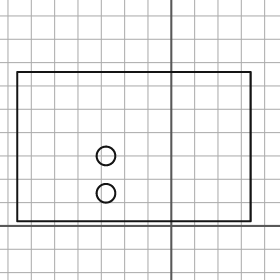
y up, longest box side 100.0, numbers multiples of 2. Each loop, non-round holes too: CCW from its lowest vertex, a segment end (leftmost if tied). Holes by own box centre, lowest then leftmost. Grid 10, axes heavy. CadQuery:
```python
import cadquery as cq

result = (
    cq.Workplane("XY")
    .moveTo(-66.0, 2.0)
    .lineTo(34.0, 2.0)
    .lineTo(34.0, 66.0)
    .lineTo(-66.0, 66.0)
    .close()
    .moveTo(-28.0, 14.0)
    .circle(4.0)
    .moveTo(-28.0, 30.0)
    .circle(4.0)
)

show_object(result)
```